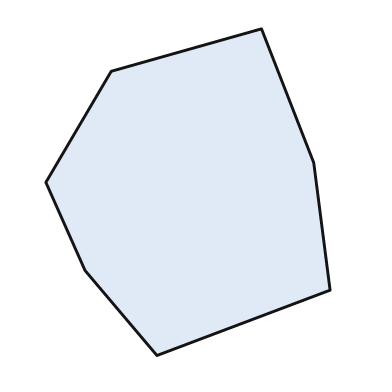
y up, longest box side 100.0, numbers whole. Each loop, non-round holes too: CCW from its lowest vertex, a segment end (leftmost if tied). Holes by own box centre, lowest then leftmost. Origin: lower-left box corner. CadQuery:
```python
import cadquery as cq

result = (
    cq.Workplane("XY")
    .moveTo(34.0, 0.0)
    .lineTo(87.0, 20.0)
    .lineTo(82.0, 59.0)
    .lineTo(66.0, 100.0)
    .lineTo(20.0, 87.0)
    .lineTo(0.0, 53.0)
    .lineTo(12.0, 26.0)
    .close()
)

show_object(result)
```